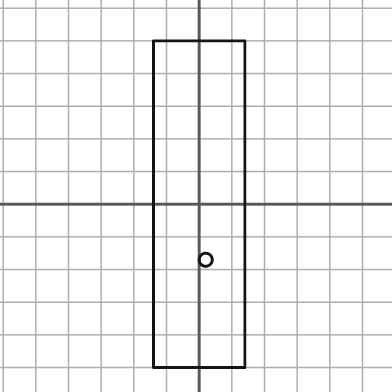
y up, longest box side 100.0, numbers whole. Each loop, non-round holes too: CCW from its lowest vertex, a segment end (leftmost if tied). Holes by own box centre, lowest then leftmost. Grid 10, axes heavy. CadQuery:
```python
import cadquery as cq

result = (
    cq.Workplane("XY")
    .moveTo(-14.0, -50.0)
    .lineTo(14.0, -50.0)
    .lineTo(14.0, 50.0)
    .lineTo(-14.0, 50.0)
    .close()
    .moveTo(2.0, -17.0)
    .circle(2.0)
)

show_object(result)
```